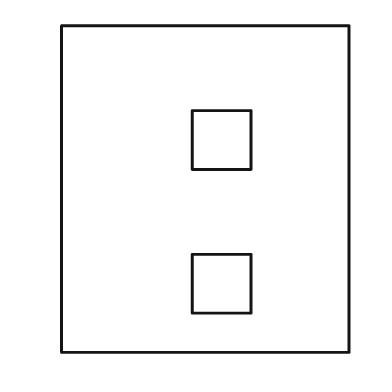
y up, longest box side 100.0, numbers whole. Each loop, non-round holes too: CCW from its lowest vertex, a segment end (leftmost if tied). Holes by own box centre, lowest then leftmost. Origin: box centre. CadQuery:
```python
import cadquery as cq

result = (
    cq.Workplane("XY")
    .moveTo(-44.0, -50.0)
    .lineTo(44.0, -50.0)
    .lineTo(44.0, 50.0)
    .lineTo(-44.0, 50.0)
    .close()
    .moveTo(-4.0, -38.0)
    .lineTo(14.0, -38.0)
    .lineTo(14.0, -20.0)
    .lineTo(-4.0, -20.0)
    .close()
    .moveTo(-4.0, 6.0)
    .lineTo(14.0, 6.0)
    .lineTo(14.0, 24.0)
    .lineTo(-4.0, 24.0)
    .close()
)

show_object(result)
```